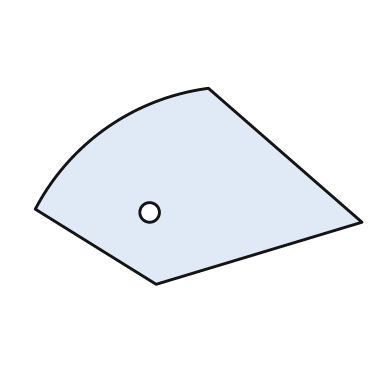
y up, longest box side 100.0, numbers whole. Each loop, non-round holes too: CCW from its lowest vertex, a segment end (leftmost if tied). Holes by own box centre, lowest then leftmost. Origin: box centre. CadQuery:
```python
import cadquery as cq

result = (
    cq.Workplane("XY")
    .moveTo(-13.0, -30.0)
    .lineTo(50.0, -11.0)
    .lineTo(3.0, 30.0)
    .threePointArc((-28.0, 18.0), (-50.0, -7.0))
    .close()
    .moveTo(-15.0, -8.0)
    .circle(3.0)
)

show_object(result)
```